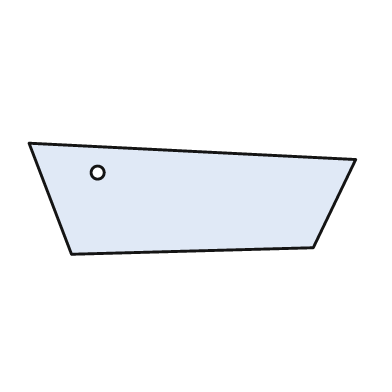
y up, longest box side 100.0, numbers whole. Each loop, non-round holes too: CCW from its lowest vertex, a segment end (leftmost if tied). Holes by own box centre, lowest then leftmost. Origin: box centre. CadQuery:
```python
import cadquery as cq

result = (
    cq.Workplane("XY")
    .moveTo(-37.0, -17.0)
    .lineTo(37.0, -15.0)
    .lineTo(50.0, 12.0)
    .lineTo(-50.0, 17.0)
    .close()
    .moveTo(-29.0, 8.0)
    .circle(2.0)
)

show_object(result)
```